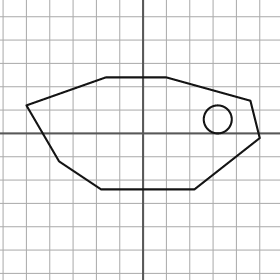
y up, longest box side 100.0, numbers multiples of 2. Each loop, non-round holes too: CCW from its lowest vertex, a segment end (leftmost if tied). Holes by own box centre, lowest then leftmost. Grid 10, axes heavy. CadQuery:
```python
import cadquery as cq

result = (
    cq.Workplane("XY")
    .moveTo(-18.0, -24.0)
    .lineTo(22.0, -24.0)
    .lineTo(50.0, -2.0)
    .lineTo(46.0, 14.0)
    .lineTo(10.0, 24.0)
    .lineTo(-16.0, 24.0)
    .lineTo(-50.0, 12.0)
    .lineTo(-36.0, -12.0)
    .close()
    .moveTo(32.0, 6.0)
    .circle(6.0)
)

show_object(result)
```